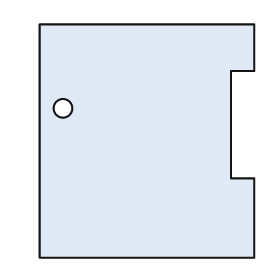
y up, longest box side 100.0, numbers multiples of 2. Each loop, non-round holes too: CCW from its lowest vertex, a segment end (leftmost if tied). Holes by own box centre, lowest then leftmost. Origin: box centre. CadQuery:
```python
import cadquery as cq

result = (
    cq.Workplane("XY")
    .moveTo(-46.0, -50.0)
    .lineTo(46.0, -50.0)
    .lineTo(46.0, -16.0)
    .lineTo(36.0, -16.0)
    .lineTo(36.0, 30.0)
    .lineTo(46.0, 30.0)
    .lineTo(46.0, 50.0)
    .lineTo(-46.0, 50.0)
    .close()
    .moveTo(-36.0, 14.0)
    .circle(4.0)
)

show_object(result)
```